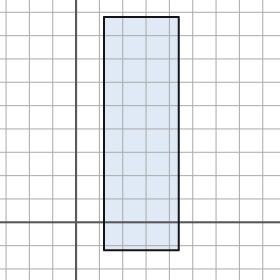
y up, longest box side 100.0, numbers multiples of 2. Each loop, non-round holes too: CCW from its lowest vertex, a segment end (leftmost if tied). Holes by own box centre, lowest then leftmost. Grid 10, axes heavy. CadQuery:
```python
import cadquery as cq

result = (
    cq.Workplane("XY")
    .moveTo(12.0, -12.0)
    .lineTo(44.0, -12.0)
    .lineTo(44.0, 88.0)
    .lineTo(12.0, 88.0)
    .close()
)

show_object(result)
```